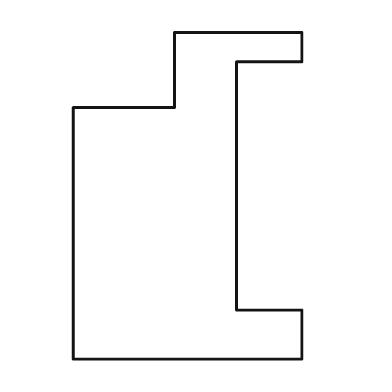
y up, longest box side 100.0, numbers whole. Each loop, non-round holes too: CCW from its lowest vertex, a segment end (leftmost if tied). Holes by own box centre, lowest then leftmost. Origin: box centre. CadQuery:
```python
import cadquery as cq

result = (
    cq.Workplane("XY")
    .moveTo(-35.0, -50.0)
    .lineTo(35.0, -50.0)
    .lineTo(35.0, -35.0)
    .lineTo(15.0, -35.0)
    .lineTo(15.0, 41.0)
    .lineTo(35.0, 41.0)
    .lineTo(35.0, 50.0)
    .lineTo(-4.0, 50.0)
    .lineTo(-4.0, 27.0)
    .lineTo(-35.0, 27.0)
    .close()
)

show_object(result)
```